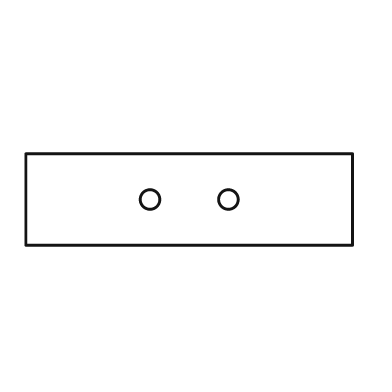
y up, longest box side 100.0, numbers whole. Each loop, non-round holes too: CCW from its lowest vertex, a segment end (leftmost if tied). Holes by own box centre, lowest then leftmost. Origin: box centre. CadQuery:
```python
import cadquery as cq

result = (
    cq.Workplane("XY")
    .moveTo(-50.0, -14.0)
    .lineTo(50.0, -14.0)
    .lineTo(50.0, 14.0)
    .lineTo(-50.0, 14.0)
    .close()
    .moveTo(-12.0, 0.0)
    .circle(3.0)
    .moveTo(12.0, 0.0)
    .circle(3.0)
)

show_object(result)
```